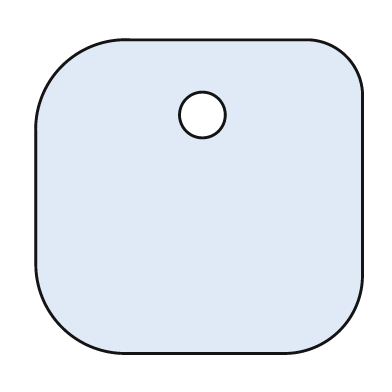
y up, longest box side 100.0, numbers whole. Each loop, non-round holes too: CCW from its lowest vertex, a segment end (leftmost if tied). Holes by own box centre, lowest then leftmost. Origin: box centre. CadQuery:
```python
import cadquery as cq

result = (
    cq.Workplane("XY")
    .moveTo(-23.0, -48.0)
    .lineTo(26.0, -48.0)
    .threePointArc((43.0, -41.0), (50.0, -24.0))
    .lineTo(50.0, 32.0)
    .threePointArc((45.0, 43.0), (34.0, 48.0))
    .lineTo(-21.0, 48.0)
    .threePointArc((-42.0, 40.0), (-50.0, 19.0))
    .lineTo(-50.0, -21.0)
    .threePointArc((-42.0, -40.0), (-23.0, -48.0))
    .close()
    .moveTo(1.0, 25.0)
    .circle(7.0)
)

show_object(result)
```